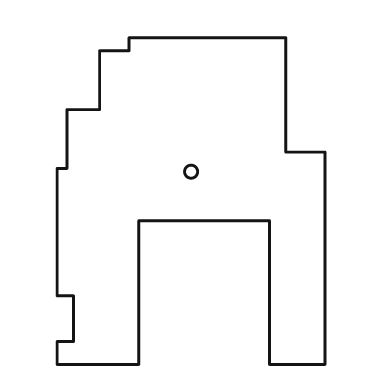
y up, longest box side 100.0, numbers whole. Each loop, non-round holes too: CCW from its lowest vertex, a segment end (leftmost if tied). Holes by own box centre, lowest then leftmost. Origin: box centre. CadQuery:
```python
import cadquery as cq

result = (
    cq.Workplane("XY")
    .moveTo(-41.0, -50.0)
    .lineTo(-16.0, -50.0)
    .lineTo(-16.0, -6.0)
    .lineTo(24.0, -6.0)
    .lineTo(24.0, -50.0)
    .lineTo(41.0, -50.0)
    .lineTo(41.0, 15.0)
    .lineTo(29.0, 15.0)
    .lineTo(29.0, 50.0)
    .lineTo(-19.0, 50.0)
    .lineTo(-19.0, 46.0)
    .lineTo(-28.0, 46.0)
    .lineTo(-28.0, 28.0)
    .lineTo(-38.0, 28.0)
    .lineTo(-38.0, 10.0)
    .lineTo(-41.0, 10.0)
    .lineTo(-41.0, -29.0)
    .lineTo(-36.0, -29.0)
    .lineTo(-36.0, -43.0)
    .lineTo(-41.0, -43.0)
    .close()
    .moveTo(0.0, 9.0)
    .circle(2.0)
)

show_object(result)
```